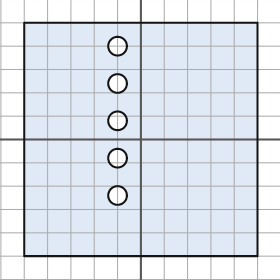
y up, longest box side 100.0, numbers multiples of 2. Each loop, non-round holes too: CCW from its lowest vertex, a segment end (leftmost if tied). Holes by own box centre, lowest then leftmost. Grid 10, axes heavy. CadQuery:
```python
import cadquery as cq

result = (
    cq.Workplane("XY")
    .moveTo(-50.0, -50.0)
    .lineTo(50.0, -50.0)
    .lineTo(50.0, 50.0)
    .lineTo(-50.0, 50.0)
    .close()
    .moveTo(-10.0, -24.0)
    .circle(4.0)
    .moveTo(-10.0, -8.0)
    .circle(4.0)
    .moveTo(-10.0, 8.0)
    .circle(4.0)
    .moveTo(-10.0, 24.0)
    .circle(4.0)
    .moveTo(-10.0, 40.0)
    .circle(4.0)
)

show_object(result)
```